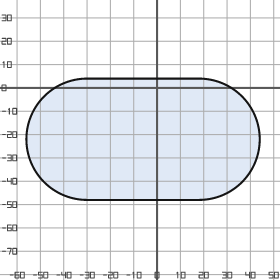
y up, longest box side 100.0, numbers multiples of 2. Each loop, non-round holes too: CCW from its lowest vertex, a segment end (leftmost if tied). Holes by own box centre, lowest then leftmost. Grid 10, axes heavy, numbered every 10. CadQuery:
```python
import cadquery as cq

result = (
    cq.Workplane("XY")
    .moveTo(-30.0, -48.0)
    .lineTo(18.0, -48.0)
    .threePointArc((44.0, -22.0), (18.0, 4.0))
    .lineTo(-30.0, 4.0)
    .threePointArc((-56.0, -22.0), (-30.0, -48.0))
    .close()
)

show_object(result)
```